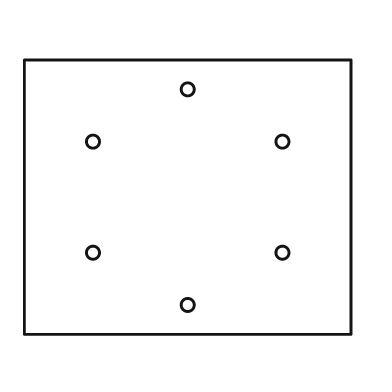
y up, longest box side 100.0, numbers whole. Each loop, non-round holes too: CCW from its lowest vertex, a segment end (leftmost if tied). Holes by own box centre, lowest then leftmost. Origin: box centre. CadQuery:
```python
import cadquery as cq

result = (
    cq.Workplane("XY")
    .moveTo(-50.0, -42.0)
    .lineTo(50.0, -42.0)
    .lineTo(50.0, 42.0)
    .lineTo(-50.0, 42.0)
    .close()
    .moveTo(0.0, -33.0)
    .circle(2.0)
    .moveTo(-29.0, -17.0)
    .circle(2.0)
    .moveTo(29.0, -17.0)
    .circle(2.0)
    .moveTo(-29.0, 17.0)
    .circle(2.0)
    .moveTo(29.0, 17.0)
    .circle(2.0)
    .moveTo(0.0, 33.0)
    .circle(2.0)
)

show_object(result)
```